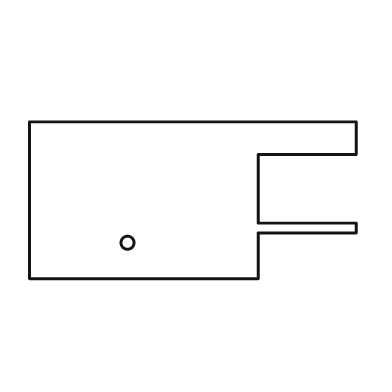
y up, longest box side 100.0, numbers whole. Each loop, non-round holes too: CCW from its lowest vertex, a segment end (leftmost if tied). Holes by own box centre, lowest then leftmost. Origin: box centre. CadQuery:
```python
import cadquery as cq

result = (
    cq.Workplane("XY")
    .moveTo(-50.0, -24.0)
    .lineTo(20.0, -24.0)
    .lineTo(20.0, -10.0)
    .lineTo(50.0, -10.0)
    .lineTo(50.0, -7.0)
    .lineTo(20.0, -7.0)
    .lineTo(20.0, 14.0)
    .lineTo(50.0, 14.0)
    .lineTo(50.0, 24.0)
    .lineTo(-50.0, 24.0)
    .close()
    .moveTo(-20.0, -13.0)
    .circle(2.0)
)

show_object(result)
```